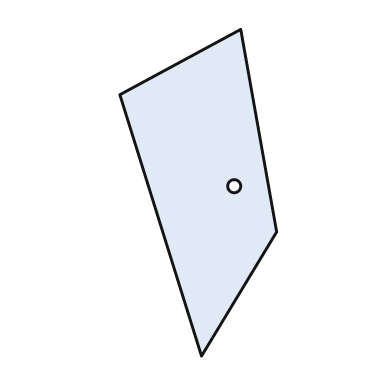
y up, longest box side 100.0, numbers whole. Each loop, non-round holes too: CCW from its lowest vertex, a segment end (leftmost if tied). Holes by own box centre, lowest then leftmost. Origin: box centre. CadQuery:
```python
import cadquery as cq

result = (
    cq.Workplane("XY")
    .moveTo(1.0, -50.0)
    .lineTo(24.0, -12.0)
    .lineTo(13.0, 50.0)
    .lineTo(-24.0, 30.0)
    .close()
    .moveTo(11.0, 2.0)
    .circle(2.0)
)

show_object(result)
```